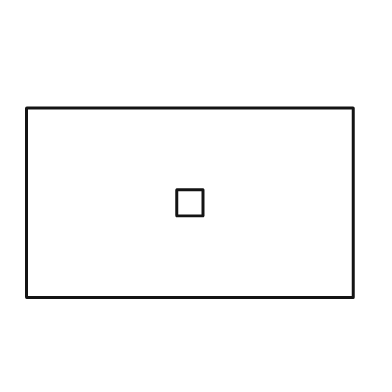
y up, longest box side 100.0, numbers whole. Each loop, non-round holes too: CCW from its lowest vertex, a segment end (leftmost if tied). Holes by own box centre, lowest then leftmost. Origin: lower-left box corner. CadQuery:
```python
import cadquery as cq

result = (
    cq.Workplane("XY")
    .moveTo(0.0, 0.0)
    .lineTo(100.0, 0.0)
    .lineTo(100.0, 58.0)
    .lineTo(0.0, 58.0)
    .close()
    .moveTo(46.0, 25.0)
    .lineTo(54.0, 25.0)
    .lineTo(54.0, 33.0)
    .lineTo(46.0, 33.0)
    .close()
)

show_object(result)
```